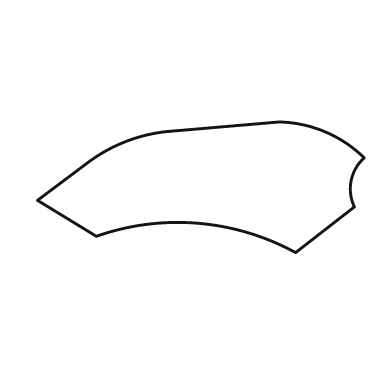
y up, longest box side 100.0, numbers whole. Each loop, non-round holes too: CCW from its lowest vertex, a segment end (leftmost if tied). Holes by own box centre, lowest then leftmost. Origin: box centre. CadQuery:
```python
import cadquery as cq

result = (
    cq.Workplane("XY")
    .moveTo(29.0, -20.0)
    .lineTo(47.0, -6.0)
    .threePointArc((46.0, 2.0), (50.0, 9.0))
    .threePointArc((38.0, 17.0), (24.0, 20.0))
    .lineTo(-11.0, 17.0)
    .threePointArc((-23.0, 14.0), (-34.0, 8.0))
    .lineTo(-50.0, -4.0)
    .lineTo(-32.0, -15.0)
    .threePointArc((-1.0, -11.0), (29.0, -20.0))
    .close()
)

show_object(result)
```